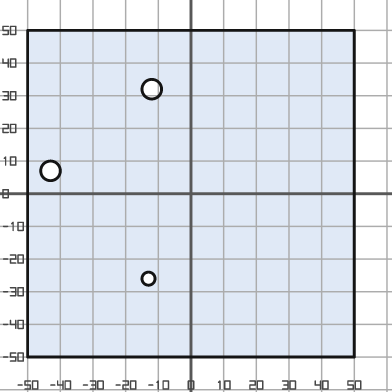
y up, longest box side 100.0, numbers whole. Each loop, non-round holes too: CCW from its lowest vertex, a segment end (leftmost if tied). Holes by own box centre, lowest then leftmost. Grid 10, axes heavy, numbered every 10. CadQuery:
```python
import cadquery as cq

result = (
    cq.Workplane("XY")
    .moveTo(-50.0, -50.0)
    .lineTo(50.0, -50.0)
    .lineTo(50.0, 50.0)
    .lineTo(-50.0, 50.0)
    .close()
    .moveTo(-13.0, -26.0)
    .circle(2.0)
    .moveTo(-43.0, 7.0)
    .circle(3.0)
    .moveTo(-12.0, 32.0)
    .circle(3.0)
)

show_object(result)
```